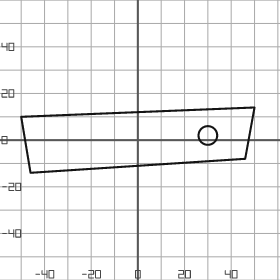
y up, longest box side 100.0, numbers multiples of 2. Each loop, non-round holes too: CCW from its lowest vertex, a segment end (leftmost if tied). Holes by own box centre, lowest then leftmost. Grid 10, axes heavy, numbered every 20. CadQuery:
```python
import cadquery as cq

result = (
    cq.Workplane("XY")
    .moveTo(-46.0, -14.0)
    .lineTo(46.0, -8.0)
    .lineTo(50.0, 14.0)
    .lineTo(-50.0, 10.0)
    .close()
    .moveTo(30.0, 2.0)
    .circle(4.0)
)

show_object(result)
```